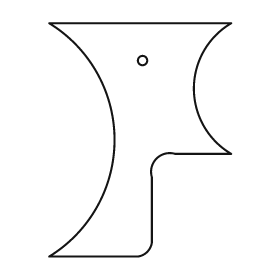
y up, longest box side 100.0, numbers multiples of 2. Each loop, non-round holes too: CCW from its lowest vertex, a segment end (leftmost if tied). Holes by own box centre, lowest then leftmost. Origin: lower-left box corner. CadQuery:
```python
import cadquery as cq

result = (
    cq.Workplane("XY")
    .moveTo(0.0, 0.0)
    .lineTo(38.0, 0.0)
    .threePointArc((42.0, 2.0), (44.0, 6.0))
    .lineTo(44.0, 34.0)
    .threePointArc((46.0, 42.0), (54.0, 44.0))
    .lineTo(78.0, 44.0)
    .threePointArc((62.0, 72.0), (78.0, 100.0))
    .lineTo(0.0, 100.0)
    .threePointArc((28.0, 50.0), (0.0, 0.0))
    .close()
    .moveTo(40.0, 84.0)
    .circle(2.0)
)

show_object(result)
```